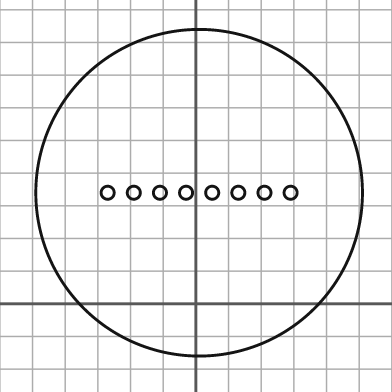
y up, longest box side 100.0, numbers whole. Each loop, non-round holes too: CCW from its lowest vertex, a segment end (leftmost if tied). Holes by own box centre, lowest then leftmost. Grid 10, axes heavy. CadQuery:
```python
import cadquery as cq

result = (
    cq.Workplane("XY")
    .moveTo(1.0, 34.0)
    .circle(50.0)
    .moveTo(-27.0, 34.0)
    .circle(2.0)
    .moveTo(-19.0, 34.0)
    .circle(2.0)
    .moveTo(-11.0, 34.0)
    .circle(2.0)
    .moveTo(-3.0, 34.0)
    .circle(2.0)
    .moveTo(5.0, 34.0)
    .circle(2.0)
    .moveTo(13.0, 34.0)
    .circle(2.0)
    .moveTo(21.0, 34.0)
    .circle(2.0)
    .moveTo(29.0, 34.0)
    .circle(2.0)
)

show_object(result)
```